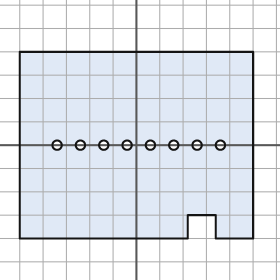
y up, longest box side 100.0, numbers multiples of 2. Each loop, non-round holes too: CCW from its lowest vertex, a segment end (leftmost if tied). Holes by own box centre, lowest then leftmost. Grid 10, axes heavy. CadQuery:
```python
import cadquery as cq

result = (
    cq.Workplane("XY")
    .moveTo(-50.0, -40.0)
    .lineTo(22.0, -40.0)
    .lineTo(22.0, -30.0)
    .lineTo(34.0, -30.0)
    .lineTo(34.0, -40.0)
    .lineTo(50.0, -40.0)
    .lineTo(50.0, 40.0)
    .lineTo(-50.0, 40.0)
    .close()
    .moveTo(-34.0, 0.0)
    .circle(2.0)
    .moveTo(-24.0, 0.0)
    .circle(2.0)
    .moveTo(-14.0, 0.0)
    .circle(2.0)
    .moveTo(-4.0, 0.0)
    .circle(2.0)
    .moveTo(6.0, 0.0)
    .circle(2.0)
    .moveTo(16.0, 0.0)
    .circle(2.0)
    .moveTo(26.0, 0.0)
    .circle(2.0)
    .moveTo(36.0, 0.0)
    .circle(2.0)
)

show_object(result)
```